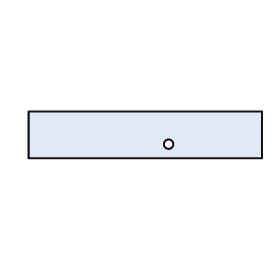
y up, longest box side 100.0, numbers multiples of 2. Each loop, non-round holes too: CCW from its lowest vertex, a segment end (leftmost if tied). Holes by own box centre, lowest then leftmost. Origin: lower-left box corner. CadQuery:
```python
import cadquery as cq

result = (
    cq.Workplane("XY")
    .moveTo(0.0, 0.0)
    .lineTo(100.0, 0.0)
    .lineTo(100.0, 20.0)
    .lineTo(0.0, 20.0)
    .close()
    .moveTo(60.0, 6.0)
    .circle(2.0)
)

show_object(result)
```